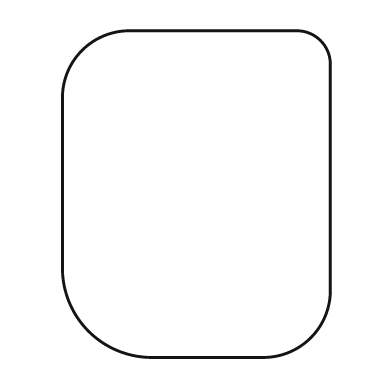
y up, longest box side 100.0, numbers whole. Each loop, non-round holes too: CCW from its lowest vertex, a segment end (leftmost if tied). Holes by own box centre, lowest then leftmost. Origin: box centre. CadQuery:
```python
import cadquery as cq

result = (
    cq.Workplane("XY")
    .moveTo(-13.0, -50.0)
    .lineTo(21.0, -50.0)
    .threePointArc((35.0, -44.0), (41.0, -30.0))
    .lineTo(41.0, 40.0)
    .threePointArc((38.0, 47.0), (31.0, 50.0))
    .lineTo(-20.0, 50.0)
    .threePointArc((-35.0, 44.0), (-41.0, 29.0))
    .lineTo(-41.0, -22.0)
    .threePointArc((-33.0, -42.0), (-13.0, -50.0))
    .close()
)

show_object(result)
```